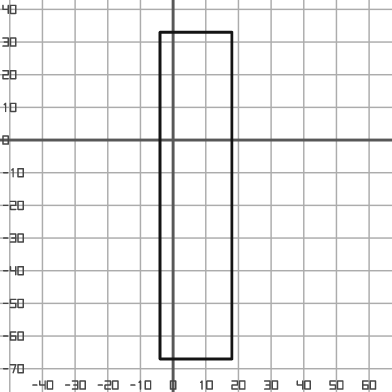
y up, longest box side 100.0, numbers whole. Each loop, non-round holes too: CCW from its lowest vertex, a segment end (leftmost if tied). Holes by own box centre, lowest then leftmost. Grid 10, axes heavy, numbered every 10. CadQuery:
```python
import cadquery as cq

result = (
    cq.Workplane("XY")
    .moveTo(-4.0, -67.0)
    .lineTo(18.0, -67.0)
    .lineTo(18.0, 33.0)
    .lineTo(-4.0, 33.0)
    .close()
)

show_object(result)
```